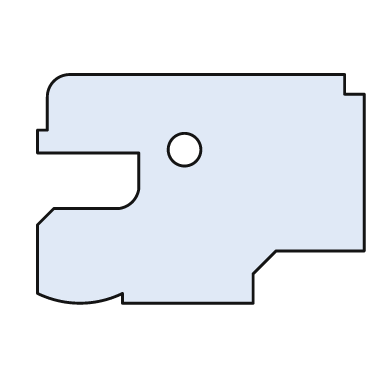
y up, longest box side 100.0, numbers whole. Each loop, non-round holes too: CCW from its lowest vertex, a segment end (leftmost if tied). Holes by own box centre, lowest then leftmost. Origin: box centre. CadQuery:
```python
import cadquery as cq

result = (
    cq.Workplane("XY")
    .moveTo(-24.0, -35.0)
    .lineTo(16.0, -35.0)
    .lineTo(16.0, -26.0)
    .lineTo(23.0, -19.0)
    .lineTo(50.0, -19.0)
    .lineTo(50.0, 29.0)
    .lineTo(44.0, 29.0)
    .lineTo(44.0, 35.0)
    .lineTo(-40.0, 35.0)
    .threePointArc((-45.0, 33.0), (-47.0, 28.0))
    .lineTo(-47.0, 18.0)
    .lineTo(-50.0, 18.0)
    .lineTo(-50.0, 11.0)
    .lineTo(-19.0, 11.0)
    .lineTo(-19.0, 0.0)
    .threePointArc((-21.0, -4.0), (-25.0, -6.0))
    .lineTo(-45.0, -6.0)
    .lineTo(-50.0, -11.0)
    .lineTo(-50.0, -32.0)
    .threePointArc((-37.0, -35.0), (-24.0, -32.0))
    .close()
    .moveTo(-5.0, 12.0)
    .circle(5.0)
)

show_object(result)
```